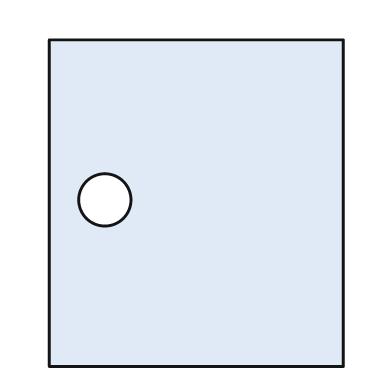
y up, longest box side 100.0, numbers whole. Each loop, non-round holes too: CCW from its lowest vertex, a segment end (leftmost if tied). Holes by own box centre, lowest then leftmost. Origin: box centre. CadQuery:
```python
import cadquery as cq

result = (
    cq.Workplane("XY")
    .moveTo(-45.0, -50.0)
    .lineTo(45.0, -50.0)
    .lineTo(45.0, 50.0)
    .lineTo(-45.0, 50.0)
    .close()
    .moveTo(-28.0, 1.0)
    .circle(8.0)
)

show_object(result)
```